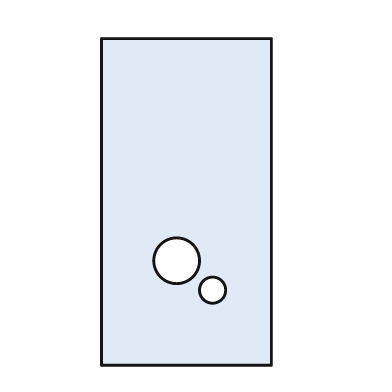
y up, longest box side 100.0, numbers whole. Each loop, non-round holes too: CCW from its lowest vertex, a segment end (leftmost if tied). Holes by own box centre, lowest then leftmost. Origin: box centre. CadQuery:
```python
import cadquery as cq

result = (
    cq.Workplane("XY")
    .moveTo(-26.0, -50.0)
    .lineTo(26.0, -50.0)
    .lineTo(26.0, 50.0)
    .lineTo(-26.0, 50.0)
    .close()
    .moveTo(8.0, -27.0)
    .circle(4.0)
    .moveTo(-3.0, -18.0)
    .circle(7.0)
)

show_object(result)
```